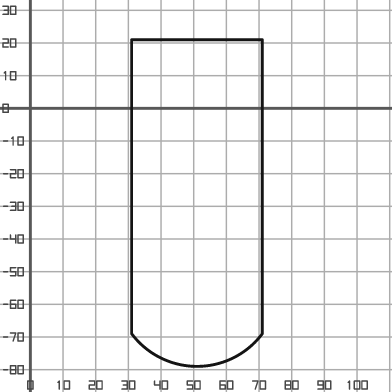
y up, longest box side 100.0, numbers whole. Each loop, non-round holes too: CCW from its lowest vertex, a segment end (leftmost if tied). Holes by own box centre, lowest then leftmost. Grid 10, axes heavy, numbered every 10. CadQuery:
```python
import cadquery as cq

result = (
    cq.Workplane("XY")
    .moveTo(31.0, -69.0)
    .threePointArc((51.0, -79.0), (71.0, -69.0))
    .lineTo(71.0, 21.0)
    .lineTo(31.0, 21.0)
    .close()
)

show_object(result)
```